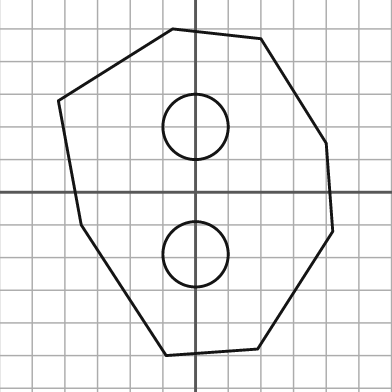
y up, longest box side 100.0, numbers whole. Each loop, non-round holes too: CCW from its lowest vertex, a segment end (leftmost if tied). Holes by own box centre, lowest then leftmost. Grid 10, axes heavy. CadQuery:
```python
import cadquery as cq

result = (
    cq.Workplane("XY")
    .moveTo(-9.0, -50.0)
    .lineTo(19.0, -48.0)
    .lineTo(42.0, -12.0)
    .lineTo(40.0, 15.0)
    .lineTo(20.0, 47.0)
    .lineTo(-7.0, 50.0)
    .lineTo(-42.0, 28.0)
    .lineTo(-35.0, -10.0)
    .close()
    .moveTo(0.0, -19.0)
    .circle(10.0)
    .moveTo(0.0, 20.0)
    .circle(10.0)
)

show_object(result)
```